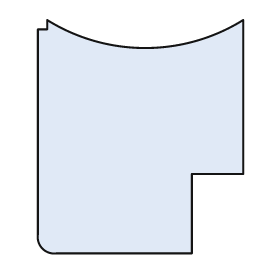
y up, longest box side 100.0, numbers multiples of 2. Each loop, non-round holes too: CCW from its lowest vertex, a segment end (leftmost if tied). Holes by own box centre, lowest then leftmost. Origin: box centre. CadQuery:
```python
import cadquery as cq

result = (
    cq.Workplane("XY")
    .moveTo(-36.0, -50.0)
    .lineTo(22.0, -50.0)
    .lineTo(22.0, -16.0)
    .lineTo(44.0, -16.0)
    .lineTo(44.0, 50.0)
    .threePointArc((2.0, 38.0), (-40.0, 50.0))
    .lineTo(-40.0, 46.0)
    .lineTo(-44.0, 46.0)
    .lineTo(-44.0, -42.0)
    .threePointArc((-42.0, -48.0), (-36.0, -50.0))
    .close()
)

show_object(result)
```